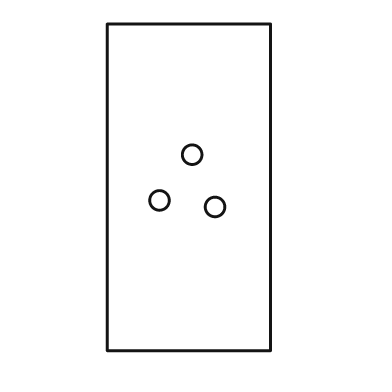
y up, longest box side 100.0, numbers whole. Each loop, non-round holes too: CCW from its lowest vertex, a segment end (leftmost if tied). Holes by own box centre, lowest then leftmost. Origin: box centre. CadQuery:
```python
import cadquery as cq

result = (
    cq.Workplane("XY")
    .moveTo(-25.0, -50.0)
    .lineTo(25.0, -50.0)
    .lineTo(25.0, 50.0)
    .lineTo(-25.0, 50.0)
    .close()
    .moveTo(8.0, -6.0)
    .circle(3.0)
    .moveTo(-9.0, -4.0)
    .circle(3.0)
    .moveTo(1.0, 10.0)
    .circle(3.0)
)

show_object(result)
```